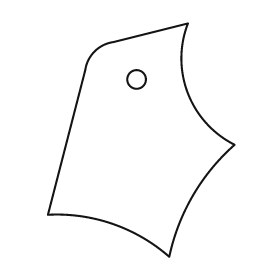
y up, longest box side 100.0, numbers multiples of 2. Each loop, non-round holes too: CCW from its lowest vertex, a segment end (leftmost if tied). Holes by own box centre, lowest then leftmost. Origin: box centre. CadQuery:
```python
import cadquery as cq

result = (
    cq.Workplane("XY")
    .moveTo(12.0, -50.0)
    .threePointArc((22.0, -24.0), (40.0, -2.0))
    .threePointArc((20.0, 20.0), (20.0, 50.0))
    .lineTo(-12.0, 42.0)
    .threePointArc((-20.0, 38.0), (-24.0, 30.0))
    .lineTo(-40.0, -32.0)
    .threePointArc((-12.0, -36.0), (12.0, -50.0))
    .close()
    .moveTo(-2.0, 26.0)
    .circle(4.0)
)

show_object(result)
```